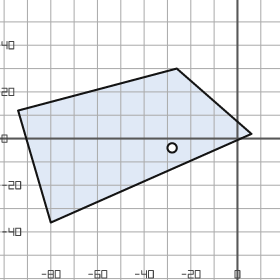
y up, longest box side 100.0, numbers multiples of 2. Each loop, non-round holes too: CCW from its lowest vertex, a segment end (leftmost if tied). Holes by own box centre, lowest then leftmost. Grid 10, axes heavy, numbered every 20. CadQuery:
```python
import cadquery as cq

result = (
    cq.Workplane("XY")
    .moveTo(-80.0, -36.0)
    .lineTo(6.0, 2.0)
    .lineTo(-26.0, 30.0)
    .lineTo(-94.0, 12.0)
    .close()
    .moveTo(-28.0, -4.0)
    .circle(2.0)
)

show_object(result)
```